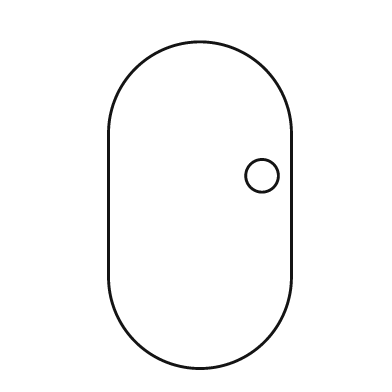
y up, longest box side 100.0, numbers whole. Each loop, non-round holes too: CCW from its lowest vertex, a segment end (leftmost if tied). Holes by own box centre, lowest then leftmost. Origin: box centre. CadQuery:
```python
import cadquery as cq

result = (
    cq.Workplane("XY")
    .moveTo(-28.0, -22.0)
    .threePointArc((0.0, -50.0), (28.0, -22.0))
    .lineTo(28.0, 22.0)
    .threePointArc((0.0, 50.0), (-28.0, 22.0))
    .close()
    .moveTo(19.0, 9.0)
    .circle(5.0)
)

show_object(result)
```